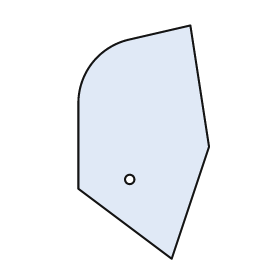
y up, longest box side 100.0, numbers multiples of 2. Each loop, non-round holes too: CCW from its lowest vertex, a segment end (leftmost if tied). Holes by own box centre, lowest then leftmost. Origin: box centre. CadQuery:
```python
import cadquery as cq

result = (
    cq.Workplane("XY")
    .moveTo(12.0, -50.0)
    .lineTo(28.0, -2.0)
    .lineTo(20.0, 50.0)
    .lineTo(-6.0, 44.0)
    .threePointArc((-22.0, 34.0), (-28.0, 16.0))
    .lineTo(-28.0, -20.0)
    .close()
    .moveTo(-6.0, -16.0)
    .circle(2.0)
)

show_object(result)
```